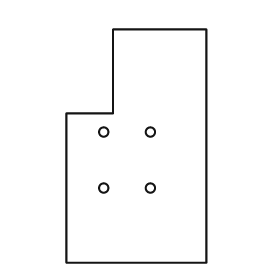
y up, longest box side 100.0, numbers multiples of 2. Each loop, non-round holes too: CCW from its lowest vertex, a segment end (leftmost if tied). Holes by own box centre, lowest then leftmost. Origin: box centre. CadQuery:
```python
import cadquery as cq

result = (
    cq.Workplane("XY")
    .moveTo(-30.0, -50.0)
    .lineTo(30.0, -50.0)
    .lineTo(30.0, 50.0)
    .lineTo(-10.0, 50.0)
    .lineTo(-10.0, 14.0)
    .lineTo(-30.0, 14.0)
    .close()
    .moveTo(-14.0, -18.0)
    .circle(2.0)
    .moveTo(6.0, -18.0)
    .circle(2.0)
    .moveTo(-14.0, 6.0)
    .circle(2.0)
    .moveTo(6.0, 6.0)
    .circle(2.0)
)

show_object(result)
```